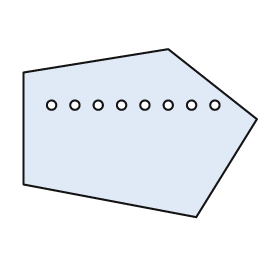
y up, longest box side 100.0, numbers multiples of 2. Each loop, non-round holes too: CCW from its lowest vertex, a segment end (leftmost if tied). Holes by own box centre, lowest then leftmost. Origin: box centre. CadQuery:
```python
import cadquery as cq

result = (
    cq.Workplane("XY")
    .moveTo(24.0, -36.0)
    .lineTo(50.0, 6.0)
    .lineTo(12.0, 36.0)
    .lineTo(-50.0, 26.0)
    .lineTo(-50.0, -22.0)
    .close()
    .moveTo(-38.0, 12.0)
    .circle(2.0)
    .moveTo(-28.0, 12.0)
    .circle(2.0)
    .moveTo(-18.0, 12.0)
    .circle(2.0)
    .moveTo(-8.0, 12.0)
    .circle(2.0)
    .moveTo(2.0, 12.0)
    .circle(2.0)
    .moveTo(12.0, 12.0)
    .circle(2.0)
    .moveTo(22.0, 12.0)
    .circle(2.0)
    .moveTo(32.0, 12.0)
    .circle(2.0)
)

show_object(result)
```